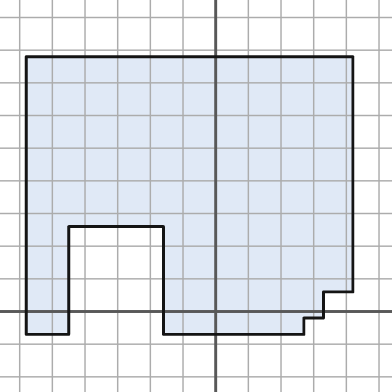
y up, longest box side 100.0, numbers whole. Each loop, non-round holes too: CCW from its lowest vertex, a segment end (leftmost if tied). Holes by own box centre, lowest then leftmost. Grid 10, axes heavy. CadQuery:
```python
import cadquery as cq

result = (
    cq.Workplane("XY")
    .moveTo(-58.0, -7.0)
    .lineTo(-45.0, -7.0)
    .lineTo(-45.0, 26.0)
    .lineTo(-16.0, 26.0)
    .lineTo(-16.0, -7.0)
    .lineTo(27.0, -7.0)
    .lineTo(27.0, -2.0)
    .lineTo(33.0, -2.0)
    .lineTo(33.0, 6.0)
    .lineTo(42.0, 6.0)
    .lineTo(42.0, 78.0)
    .lineTo(-58.0, 78.0)
    .close()
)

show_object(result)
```